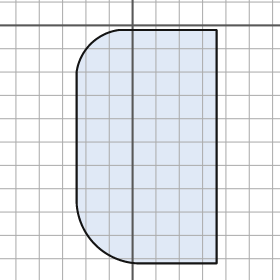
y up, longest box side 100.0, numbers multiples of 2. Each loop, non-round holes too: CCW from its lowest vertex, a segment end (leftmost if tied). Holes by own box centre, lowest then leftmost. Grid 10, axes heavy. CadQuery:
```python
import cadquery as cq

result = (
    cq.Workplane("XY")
    .moveTo(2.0, -102.0)
    .lineTo(36.0, -102.0)
    .lineTo(36.0, -2.0)
    .lineTo(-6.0, -2.0)
    .threePointArc((-18.0, -8.0), (-24.0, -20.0))
    .lineTo(-24.0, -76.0)
    .threePointArc((-16.0, -94.0), (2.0, -102.0))
    .close()
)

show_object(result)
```